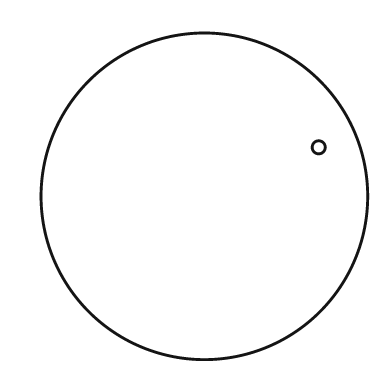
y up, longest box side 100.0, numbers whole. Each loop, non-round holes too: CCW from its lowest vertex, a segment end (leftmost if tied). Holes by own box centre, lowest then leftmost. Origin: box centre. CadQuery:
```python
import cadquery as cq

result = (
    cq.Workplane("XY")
    .moveTo(0.0, 0.0)
    .circle(50.0)
    .moveTo(35.0, 15.0)
    .circle(2.0)
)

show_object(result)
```